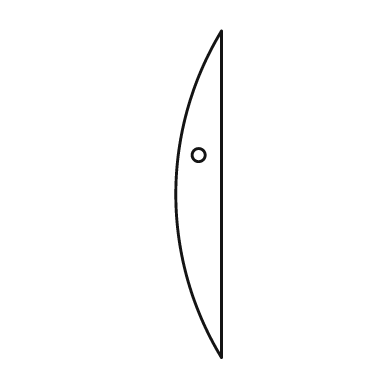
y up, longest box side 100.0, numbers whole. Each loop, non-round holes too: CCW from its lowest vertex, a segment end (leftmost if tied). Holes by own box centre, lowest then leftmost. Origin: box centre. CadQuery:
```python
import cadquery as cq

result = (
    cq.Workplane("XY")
    .moveTo(7.0, -50.0)
    .lineTo(7.0, 50.0)
    .threePointArc((-7.0, 0.0), (7.0, -50.0))
    .close()
    .moveTo(0.0, 12.0)
    .circle(2.0)
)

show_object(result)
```